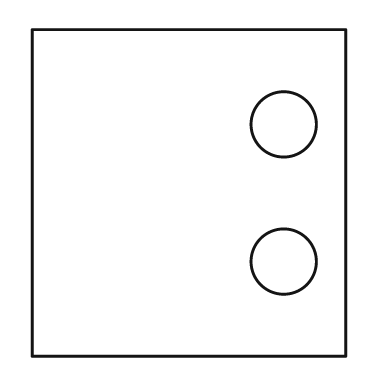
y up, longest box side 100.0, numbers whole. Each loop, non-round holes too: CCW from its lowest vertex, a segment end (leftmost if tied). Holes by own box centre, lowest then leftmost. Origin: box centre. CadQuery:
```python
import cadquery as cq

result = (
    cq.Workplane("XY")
    .moveTo(-48.0, -50.0)
    .lineTo(48.0, -50.0)
    .lineTo(48.0, 50.0)
    .lineTo(-48.0, 50.0)
    .close()
    .moveTo(29.0, -21.0)
    .circle(10.0)
    .moveTo(29.0, 21.0)
    .circle(10.0)
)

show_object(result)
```